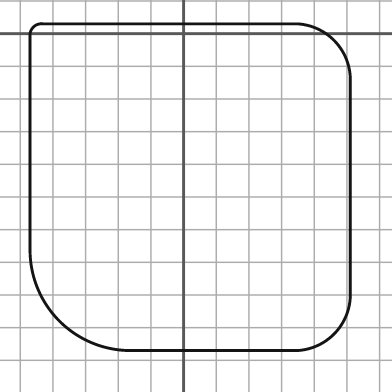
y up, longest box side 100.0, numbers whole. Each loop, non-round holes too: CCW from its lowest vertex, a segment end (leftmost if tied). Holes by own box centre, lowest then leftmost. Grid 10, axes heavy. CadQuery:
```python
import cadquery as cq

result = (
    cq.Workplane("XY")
    .moveTo(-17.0, -97.0)
    .lineTo(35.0, -97.0)
    .threePointArc((46.0, -92.0), (51.0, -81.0))
    .lineTo(51.0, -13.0)
    .threePointArc((46.0, -2.0), (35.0, 3.0))
    .lineTo(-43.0, 3.0)
    .threePointArc((-46.0, 2.0), (-47.0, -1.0))
    .lineTo(-47.0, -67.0)
    .threePointArc((-38.0, -88.0), (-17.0, -97.0))
    .close()
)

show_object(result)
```